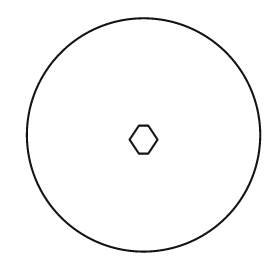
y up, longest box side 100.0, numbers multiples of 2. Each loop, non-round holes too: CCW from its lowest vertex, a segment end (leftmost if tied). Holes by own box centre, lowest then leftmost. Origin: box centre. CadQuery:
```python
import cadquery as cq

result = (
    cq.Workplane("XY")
    .moveTo(0.0, 0.0)
    .circle(50.0)
    .moveTo(-2.0, -8.0)
    .lineTo(2.0, -8.0)
    .lineTo(6.0, -2.0)
    .lineTo(2.0, 4.0)
    .lineTo(-2.0, 4.0)
    .lineTo(-6.0, -2.0)
    .close()
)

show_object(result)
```